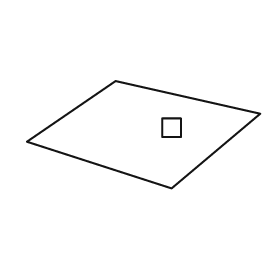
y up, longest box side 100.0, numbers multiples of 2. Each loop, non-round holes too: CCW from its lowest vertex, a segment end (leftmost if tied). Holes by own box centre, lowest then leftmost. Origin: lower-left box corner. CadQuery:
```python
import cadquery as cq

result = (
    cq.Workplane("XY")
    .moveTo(62.0, 0.0)
    .lineTo(100.0, 32.0)
    .lineTo(38.0, 46.0)
    .lineTo(0.0, 20.0)
    .close()
    .moveTo(58.0, 22.0)
    .lineTo(66.0, 22.0)
    .lineTo(66.0, 30.0)
    .lineTo(58.0, 30.0)
    .close()
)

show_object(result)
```